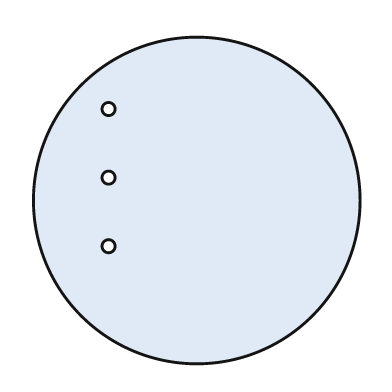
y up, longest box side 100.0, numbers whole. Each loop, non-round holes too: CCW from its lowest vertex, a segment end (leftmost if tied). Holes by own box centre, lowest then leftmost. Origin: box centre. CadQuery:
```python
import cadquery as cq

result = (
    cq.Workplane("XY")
    .moveTo(0.0, 0.0)
    .circle(50.0)
    .moveTo(-27.0, -14.0)
    .circle(2.0)
    .moveTo(-27.0, 7.0)
    .circle(2.0)
    .moveTo(-27.0, 28.0)
    .circle(2.0)
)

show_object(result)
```